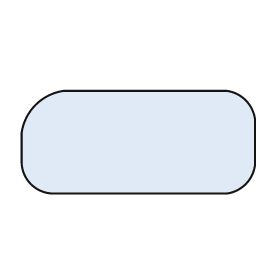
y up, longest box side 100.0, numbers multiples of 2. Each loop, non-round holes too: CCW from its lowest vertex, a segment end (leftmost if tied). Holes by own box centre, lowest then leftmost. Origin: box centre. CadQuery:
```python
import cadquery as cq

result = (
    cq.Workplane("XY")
    .moveTo(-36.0, -22.0)
    .lineTo(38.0, -22.0)
    .threePointArc((46.0, -18.0), (50.0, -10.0))
    .lineTo(50.0, 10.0)
    .threePointArc((46.0, 18.0), (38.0, 22.0))
    .lineTo(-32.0, 22.0)
    .threePointArc((-44.0, 16.0), (-50.0, 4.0))
    .lineTo(-50.0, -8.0)
    .threePointArc((-46.0, -18.0), (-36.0, -22.0))
    .close()
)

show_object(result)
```